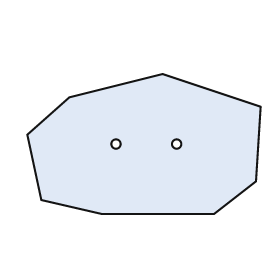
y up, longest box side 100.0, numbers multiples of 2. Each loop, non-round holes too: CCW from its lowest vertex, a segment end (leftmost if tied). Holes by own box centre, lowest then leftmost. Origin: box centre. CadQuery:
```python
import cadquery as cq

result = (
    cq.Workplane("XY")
    .moveTo(-18.0, -30.0)
    .lineTo(30.0, -30.0)
    .lineTo(48.0, -16.0)
    .lineTo(50.0, 16.0)
    .lineTo(8.0, 30.0)
    .lineTo(-32.0, 20.0)
    .lineTo(-50.0, 4.0)
    .lineTo(-44.0, -24.0)
    .close()
    .moveTo(-12.0, 0.0)
    .circle(2.0)
    .moveTo(14.0, 0.0)
    .circle(2.0)
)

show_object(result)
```